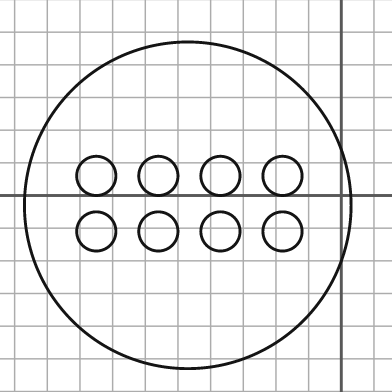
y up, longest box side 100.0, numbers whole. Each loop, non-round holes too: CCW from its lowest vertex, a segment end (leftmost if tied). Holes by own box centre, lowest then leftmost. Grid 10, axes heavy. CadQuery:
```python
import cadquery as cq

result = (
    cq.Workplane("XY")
    .moveTo(-47.0, -3.0)
    .circle(50.0)
    .moveTo(-75.0, -11.0)
    .circle(6.0)
    .moveTo(-56.0, -11.0)
    .circle(6.0)
    .moveTo(-37.0, -11.0)
    .circle(6.0)
    .moveTo(-18.0, -11.0)
    .circle(6.0)
    .moveTo(-75.0, 6.0)
    .circle(6.0)
    .moveTo(-56.0, 6.0)
    .circle(6.0)
    .moveTo(-37.0, 6.0)
    .circle(6.0)
    .moveTo(-18.0, 6.0)
    .circle(6.0)
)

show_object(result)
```